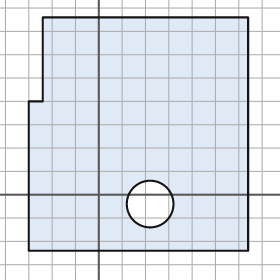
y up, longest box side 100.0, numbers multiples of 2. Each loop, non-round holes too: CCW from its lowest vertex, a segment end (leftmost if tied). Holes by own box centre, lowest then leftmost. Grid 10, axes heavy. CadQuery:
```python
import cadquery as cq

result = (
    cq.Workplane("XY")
    .moveTo(-30.0, -24.0)
    .lineTo(64.0, -24.0)
    .lineTo(64.0, 76.0)
    .lineTo(-24.0, 76.0)
    .lineTo(-24.0, 40.0)
    .lineTo(-30.0, 40.0)
    .close()
    .moveTo(22.0, -4.0)
    .circle(10.0)
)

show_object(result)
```